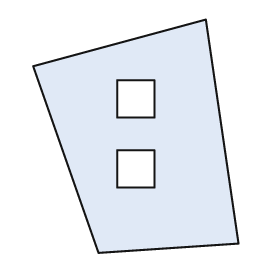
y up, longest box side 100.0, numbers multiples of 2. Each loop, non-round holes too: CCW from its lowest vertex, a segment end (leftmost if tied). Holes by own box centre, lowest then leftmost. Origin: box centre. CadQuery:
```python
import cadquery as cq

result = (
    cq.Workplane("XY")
    .moveTo(-16.0, -50.0)
    .lineTo(44.0, -46.0)
    .lineTo(30.0, 50.0)
    .lineTo(-44.0, 30.0)
    .close()
    .moveTo(-8.0, -22.0)
    .lineTo(8.0, -22.0)
    .lineTo(8.0, -6.0)
    .lineTo(-8.0, -6.0)
    .close()
    .moveTo(-8.0, 8.0)
    .lineTo(8.0, 8.0)
    .lineTo(8.0, 24.0)
    .lineTo(-8.0, 24.0)
    .close()
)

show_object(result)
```